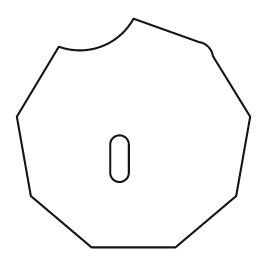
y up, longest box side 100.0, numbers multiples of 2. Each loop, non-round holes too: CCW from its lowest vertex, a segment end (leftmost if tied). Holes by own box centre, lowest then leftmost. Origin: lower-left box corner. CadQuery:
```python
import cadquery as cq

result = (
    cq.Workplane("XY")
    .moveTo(32.0, 0.0)
    .lineTo(68.0, 0.0)
    .lineTo(94.0, 22.0)
    .lineTo(100.0, 56.0)
    .lineTo(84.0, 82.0)
    .threePointArc((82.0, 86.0), (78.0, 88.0))
    .lineTo(50.0, 98.0)
    .threePointArc((36.0, 86.0), (18.0, 86.0))
    .lineTo(0.0, 56.0)
    .lineTo(6.0, 22.0)
    .close()
    .moveTo(40.0, 32.0)
    .threePointArc((44.0, 28.0), (48.0, 32.0))
    .lineTo(48.0, 44.0)
    .threePointArc((44.0, 48.0), (40.0, 44.0))
    .close()
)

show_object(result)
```